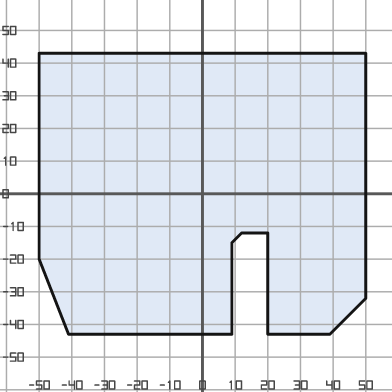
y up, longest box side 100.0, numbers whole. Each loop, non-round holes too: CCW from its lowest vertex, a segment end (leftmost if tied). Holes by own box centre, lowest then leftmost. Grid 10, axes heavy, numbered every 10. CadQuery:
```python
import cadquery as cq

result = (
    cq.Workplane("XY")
    .moveTo(-41.0, -43.0)
    .lineTo(9.0, -43.0)
    .lineTo(9.0, -15.0)
    .lineTo(12.0, -12.0)
    .lineTo(20.0, -12.0)
    .lineTo(20.0, -43.0)
    .lineTo(39.0, -43.0)
    .lineTo(50.0, -32.0)
    .lineTo(50.0, 43.0)
    .lineTo(-50.0, 43.0)
    .lineTo(-50.0, -20.0)
    .close()
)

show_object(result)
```